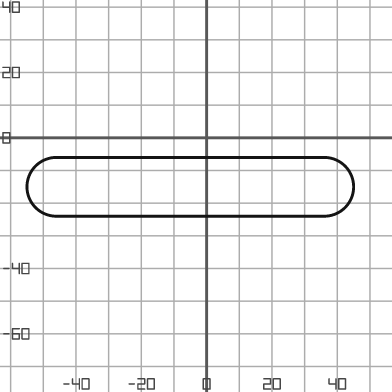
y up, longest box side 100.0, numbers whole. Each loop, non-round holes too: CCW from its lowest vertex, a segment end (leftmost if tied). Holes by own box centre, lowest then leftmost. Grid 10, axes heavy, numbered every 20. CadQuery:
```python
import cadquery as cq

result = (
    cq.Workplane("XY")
    .moveTo(-46.0, -24.0)
    .lineTo(36.0, -24.0)
    .threePointArc((45.0, -15.0), (36.0, -6.0))
    .lineTo(-46.0, -6.0)
    .threePointArc((-55.0, -15.0), (-46.0, -24.0))
    .close()
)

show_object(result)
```